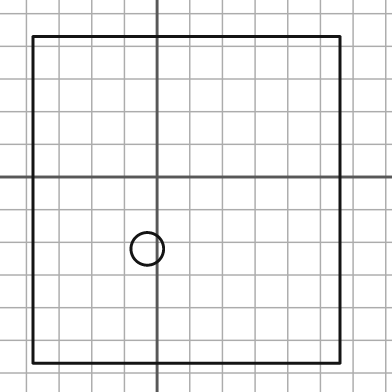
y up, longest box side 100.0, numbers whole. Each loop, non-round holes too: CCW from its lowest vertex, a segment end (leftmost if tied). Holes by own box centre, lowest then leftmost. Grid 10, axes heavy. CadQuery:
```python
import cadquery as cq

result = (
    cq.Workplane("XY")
    .moveTo(-38.0, -57.0)
    .lineTo(56.0, -57.0)
    .lineTo(56.0, 43.0)
    .lineTo(-38.0, 43.0)
    .close()
    .moveTo(-3.0, -22.0)
    .circle(5.0)
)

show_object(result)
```